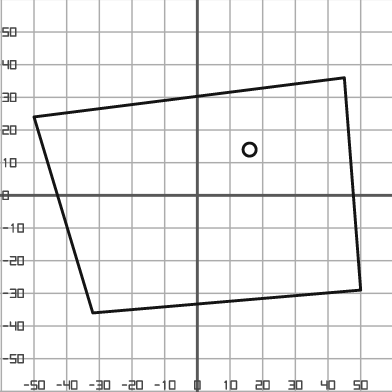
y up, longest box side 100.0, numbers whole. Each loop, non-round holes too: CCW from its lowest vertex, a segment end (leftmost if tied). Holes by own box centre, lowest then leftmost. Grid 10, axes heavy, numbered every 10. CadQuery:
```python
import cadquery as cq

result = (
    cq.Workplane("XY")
    .moveTo(-32.0, -36.0)
    .lineTo(50.0, -29.0)
    .lineTo(45.0, 36.0)
    .lineTo(-50.0, 24.0)
    .close()
    .moveTo(16.0, 14.0)
    .circle(2.0)
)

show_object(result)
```